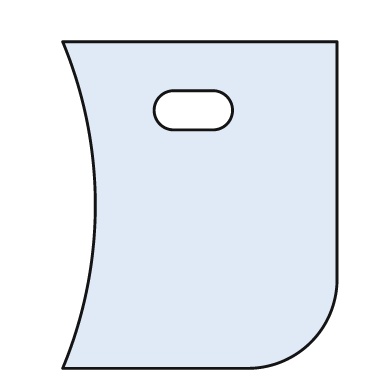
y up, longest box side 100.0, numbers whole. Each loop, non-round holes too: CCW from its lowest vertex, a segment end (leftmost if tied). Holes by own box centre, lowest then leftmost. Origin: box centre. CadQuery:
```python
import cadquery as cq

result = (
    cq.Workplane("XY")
    .moveTo(-42.0, -50.0)
    .lineTo(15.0, -50.0)
    .threePointArc((34.0, -42.0), (42.0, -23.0))
    .lineTo(42.0, 50.0)
    .lineTo(-42.0, 50.0)
    .threePointArc((-32.0, 0.0), (-42.0, -50.0))
    .close()
    .moveTo(-8.0, 23.0)
    .lineTo(4.0, 23.0)
    .threePointArc((10.0, 29.0), (4.0, 35.0))
    .lineTo(-8.0, 35.0)
    .threePointArc((-14.0, 29.0), (-8.0, 23.0))
    .close()
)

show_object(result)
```